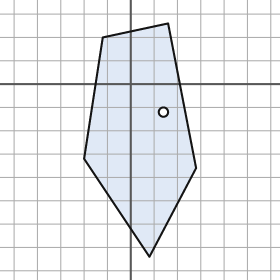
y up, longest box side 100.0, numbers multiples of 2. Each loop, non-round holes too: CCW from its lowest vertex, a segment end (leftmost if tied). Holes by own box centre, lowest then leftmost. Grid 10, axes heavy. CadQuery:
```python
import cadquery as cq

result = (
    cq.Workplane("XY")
    .moveTo(8.0, -74.0)
    .lineTo(28.0, -36.0)
    .lineTo(16.0, 26.0)
    .lineTo(-12.0, 20.0)
    .lineTo(-20.0, -32.0)
    .close()
    .moveTo(14.0, -12.0)
    .circle(2.0)
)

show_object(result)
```